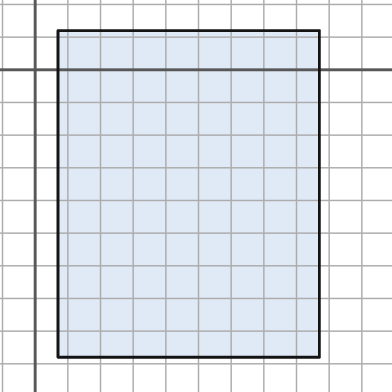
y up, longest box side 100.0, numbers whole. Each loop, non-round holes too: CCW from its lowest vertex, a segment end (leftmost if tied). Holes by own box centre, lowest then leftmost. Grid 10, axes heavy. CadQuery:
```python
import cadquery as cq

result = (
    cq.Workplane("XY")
    .moveTo(7.0, -88.0)
    .lineTo(87.0, -88.0)
    .lineTo(87.0, 12.0)
    .lineTo(7.0, 12.0)
    .close()
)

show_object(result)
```